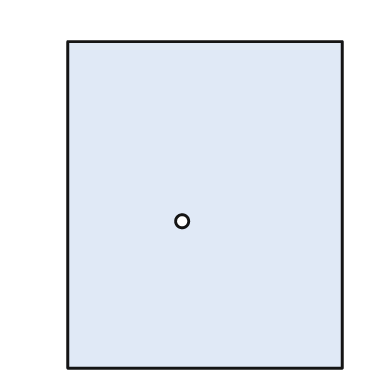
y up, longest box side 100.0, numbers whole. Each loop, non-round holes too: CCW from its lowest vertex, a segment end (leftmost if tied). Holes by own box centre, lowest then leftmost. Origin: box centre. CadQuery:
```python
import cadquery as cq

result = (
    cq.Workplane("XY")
    .moveTo(-42.0, -50.0)
    .lineTo(42.0, -50.0)
    .lineTo(42.0, 50.0)
    .lineTo(-42.0, 50.0)
    .close()
    .moveTo(-7.0, -5.0)
    .circle(2.0)
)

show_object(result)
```